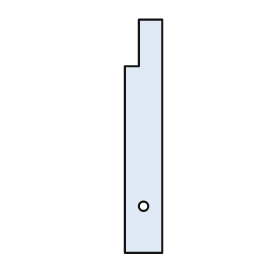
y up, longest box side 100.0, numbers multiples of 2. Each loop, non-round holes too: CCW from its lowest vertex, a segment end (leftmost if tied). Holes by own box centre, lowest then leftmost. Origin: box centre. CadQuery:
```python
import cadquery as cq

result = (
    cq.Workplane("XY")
    .moveTo(-8.0, -50.0)
    .lineTo(8.0, -50.0)
    .lineTo(8.0, 50.0)
    .lineTo(-2.0, 50.0)
    .lineTo(-2.0, 30.0)
    .lineTo(-8.0, 30.0)
    .close()
    .moveTo(0.0, -30.0)
    .circle(2.0)
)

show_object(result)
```